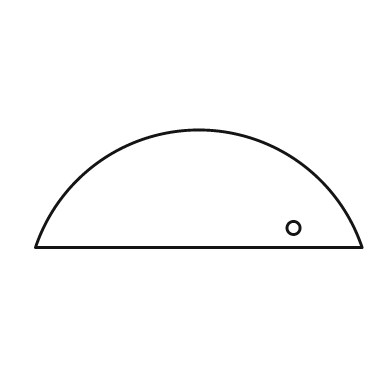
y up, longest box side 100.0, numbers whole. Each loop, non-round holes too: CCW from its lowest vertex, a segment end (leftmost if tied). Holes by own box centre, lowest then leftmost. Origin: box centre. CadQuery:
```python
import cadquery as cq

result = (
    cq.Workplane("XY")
    .moveTo(-50.0, -18.0)
    .lineTo(50.0, -18.0)
    .threePointArc((0.0, 18.0), (-50.0, -18.0))
    .close()
    .moveTo(29.0, -12.0)
    .circle(2.0)
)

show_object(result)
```